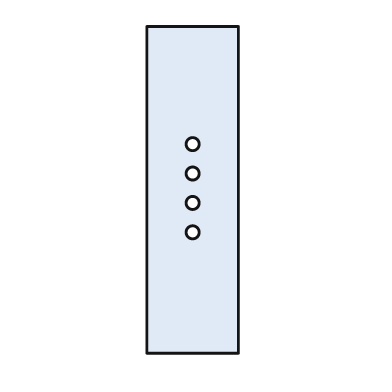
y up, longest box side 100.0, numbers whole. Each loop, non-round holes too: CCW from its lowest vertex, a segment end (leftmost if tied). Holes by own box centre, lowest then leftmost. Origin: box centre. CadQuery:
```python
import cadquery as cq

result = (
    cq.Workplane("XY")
    .moveTo(-14.0, -50.0)
    .lineTo(14.0, -50.0)
    .lineTo(14.0, 50.0)
    .lineTo(-14.0, 50.0)
    .close()
    .moveTo(0.0, -13.0)
    .circle(2.0)
    .moveTo(0.0, -4.0)
    .circle(2.0)
    .moveTo(0.0, 5.0)
    .circle(2.0)
    .moveTo(0.0, 14.0)
    .circle(2.0)
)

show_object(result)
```